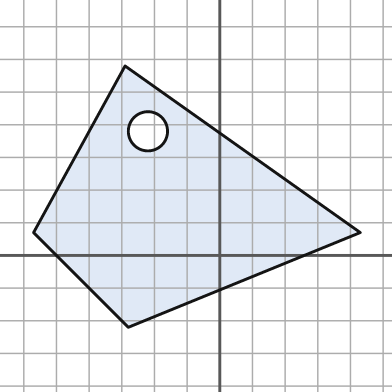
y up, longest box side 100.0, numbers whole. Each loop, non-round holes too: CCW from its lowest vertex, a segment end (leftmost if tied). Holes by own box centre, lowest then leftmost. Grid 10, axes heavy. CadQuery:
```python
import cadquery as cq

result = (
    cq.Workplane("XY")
    .moveTo(-28.0, -22.0)
    .lineTo(43.0, 7.0)
    .lineTo(-29.0, 58.0)
    .lineTo(-57.0, 7.0)
    .close()
    .moveTo(-22.0, 38.0)
    .circle(6.0)
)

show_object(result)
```